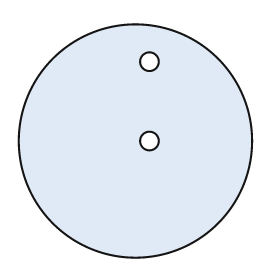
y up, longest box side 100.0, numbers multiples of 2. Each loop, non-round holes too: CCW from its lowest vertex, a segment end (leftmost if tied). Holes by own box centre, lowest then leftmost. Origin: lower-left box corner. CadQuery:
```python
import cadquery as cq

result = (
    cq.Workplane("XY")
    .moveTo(50.0, 50.0)
    .circle(50.0)
    .moveTo(56.0, 50.0)
    .circle(4.0)
    .moveTo(56.0, 84.0)
    .circle(4.0)
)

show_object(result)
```